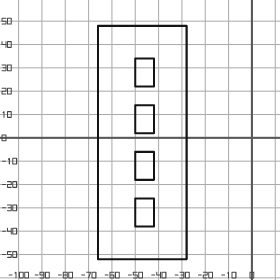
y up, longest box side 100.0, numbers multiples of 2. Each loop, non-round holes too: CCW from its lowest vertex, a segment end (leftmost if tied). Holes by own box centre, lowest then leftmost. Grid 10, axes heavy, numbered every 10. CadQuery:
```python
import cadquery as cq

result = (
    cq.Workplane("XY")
    .moveTo(-66.0, -52.0)
    .lineTo(-28.0, -52.0)
    .lineTo(-28.0, 48.0)
    .lineTo(-66.0, 48.0)
    .close()
    .moveTo(-50.0, -38.0)
    .lineTo(-42.0, -38.0)
    .lineTo(-42.0, -26.0)
    .lineTo(-50.0, -26.0)
    .close()
    .moveTo(-50.0, -18.0)
    .lineTo(-42.0, -18.0)
    .lineTo(-42.0, -6.0)
    .lineTo(-50.0, -6.0)
    .close()
    .moveTo(-50.0, 2.0)
    .lineTo(-42.0, 2.0)
    .lineTo(-42.0, 14.0)
    .lineTo(-50.0, 14.0)
    .close()
    .moveTo(-50.0, 22.0)
    .lineTo(-42.0, 22.0)
    .lineTo(-42.0, 34.0)
    .lineTo(-50.0, 34.0)
    .close()
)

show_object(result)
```